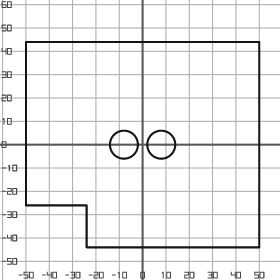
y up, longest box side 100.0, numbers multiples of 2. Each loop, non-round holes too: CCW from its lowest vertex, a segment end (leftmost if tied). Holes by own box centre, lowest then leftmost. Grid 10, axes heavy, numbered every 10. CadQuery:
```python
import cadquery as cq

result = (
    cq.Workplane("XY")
    .moveTo(-24.0, -44.0)
    .lineTo(50.0, -44.0)
    .lineTo(50.0, 44.0)
    .lineTo(-50.0, 44.0)
    .lineTo(-50.0, -26.0)
    .lineTo(-24.0, -26.0)
    .close()
    .moveTo(-8.0, 0.0)
    .circle(6.0)
    .moveTo(8.0, 0.0)
    .circle(6.0)
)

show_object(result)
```